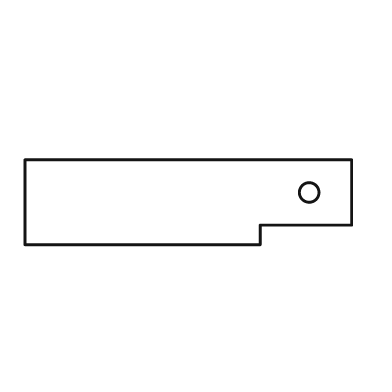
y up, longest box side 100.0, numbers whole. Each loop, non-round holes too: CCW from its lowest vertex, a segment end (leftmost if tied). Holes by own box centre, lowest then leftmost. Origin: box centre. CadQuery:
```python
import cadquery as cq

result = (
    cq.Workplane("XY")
    .moveTo(-50.0, -13.0)
    .lineTo(22.0, -13.0)
    .lineTo(22.0, -7.0)
    .lineTo(50.0, -7.0)
    .lineTo(50.0, 13.0)
    .lineTo(-50.0, 13.0)
    .close()
    .moveTo(37.0, 3.0)
    .circle(3.0)
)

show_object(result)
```